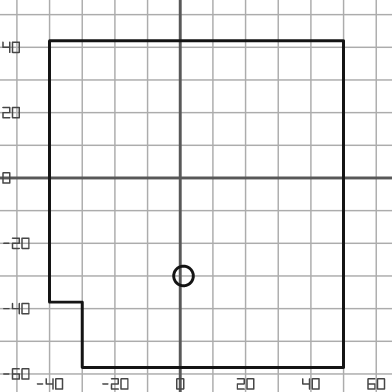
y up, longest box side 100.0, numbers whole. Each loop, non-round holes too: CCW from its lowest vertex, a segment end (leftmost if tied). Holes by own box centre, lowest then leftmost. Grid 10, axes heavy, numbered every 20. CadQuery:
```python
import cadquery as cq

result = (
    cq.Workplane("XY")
    .moveTo(-30.0, -58.0)
    .lineTo(50.0, -58.0)
    .lineTo(50.0, 42.0)
    .lineTo(-40.0, 42.0)
    .lineTo(-40.0, -38.0)
    .lineTo(-30.0, -38.0)
    .close()
    .moveTo(1.0, -30.0)
    .circle(3.0)
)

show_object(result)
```